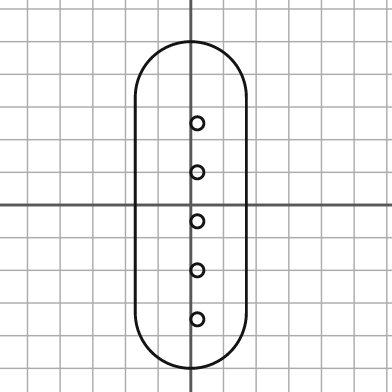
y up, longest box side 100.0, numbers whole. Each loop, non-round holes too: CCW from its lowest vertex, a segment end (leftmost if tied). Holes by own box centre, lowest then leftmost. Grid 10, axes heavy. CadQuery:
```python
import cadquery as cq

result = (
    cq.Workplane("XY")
    .moveTo(-17.0, -33.0)
    .threePointArc((0.0, -50.0), (17.0, -33.0))
    .lineTo(17.0, 33.0)
    .threePointArc((0.0, 50.0), (-17.0, 33.0))
    .close()
    .moveTo(2.0, -35.0)
    .circle(2.0)
    .moveTo(2.0, -20.0)
    .circle(2.0)
    .moveTo(2.0, -5.0)
    .circle(2.0)
    .moveTo(2.0, 10.0)
    .circle(2.0)
    .moveTo(2.0, 25.0)
    .circle(2.0)
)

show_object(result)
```